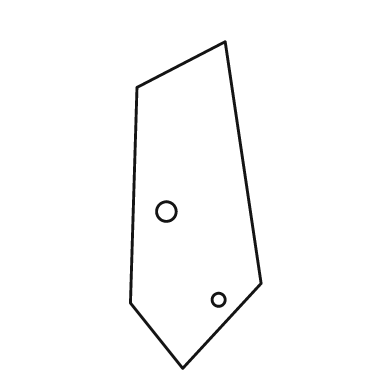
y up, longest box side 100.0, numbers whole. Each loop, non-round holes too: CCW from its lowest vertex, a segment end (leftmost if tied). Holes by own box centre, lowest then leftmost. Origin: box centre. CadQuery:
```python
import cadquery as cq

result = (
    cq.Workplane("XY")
    .moveTo(-4.0, -50.0)
    .lineTo(20.0, -24.0)
    .lineTo(9.0, 50.0)
    .lineTo(-18.0, 36.0)
    .lineTo(-20.0, -30.0)
    .close()
    .moveTo(7.0, -29.0)
    .circle(2.0)
    .moveTo(-9.0, -2.0)
    .circle(3.0)
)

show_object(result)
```